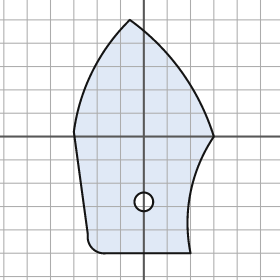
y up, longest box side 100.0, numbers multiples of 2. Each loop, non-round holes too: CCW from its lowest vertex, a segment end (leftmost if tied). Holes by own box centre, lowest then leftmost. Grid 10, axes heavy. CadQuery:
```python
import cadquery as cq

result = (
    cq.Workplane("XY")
    .moveTo(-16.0, -50.0)
    .lineTo(20.0, -50.0)
    .threePointArc((20.0, -24.0), (30.0, 0.0))
    .threePointArc((16.0, 28.0), (-6.0, 50.0))
    .threePointArc((-22.0, 28.0), (-30.0, 2.0))
    .lineTo(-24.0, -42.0)
    .threePointArc((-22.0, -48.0), (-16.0, -50.0))
    .close()
    .moveTo(0.0, -28.0)
    .circle(4.0)
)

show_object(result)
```